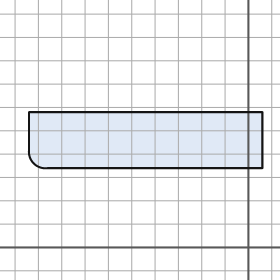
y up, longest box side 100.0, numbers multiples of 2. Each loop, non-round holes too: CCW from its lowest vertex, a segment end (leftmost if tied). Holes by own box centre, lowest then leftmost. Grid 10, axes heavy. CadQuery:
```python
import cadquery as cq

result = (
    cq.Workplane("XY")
    .moveTo(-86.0, 34.0)
    .lineTo(6.0, 34.0)
    .lineTo(6.0, 58.0)
    .lineTo(-94.0, 58.0)
    .lineTo(-94.0, 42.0)
    .threePointArc((-92.0, 36.0), (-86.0, 34.0))
    .close()
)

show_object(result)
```